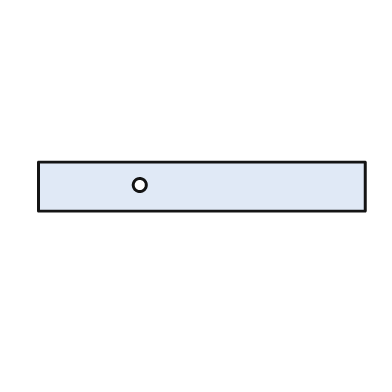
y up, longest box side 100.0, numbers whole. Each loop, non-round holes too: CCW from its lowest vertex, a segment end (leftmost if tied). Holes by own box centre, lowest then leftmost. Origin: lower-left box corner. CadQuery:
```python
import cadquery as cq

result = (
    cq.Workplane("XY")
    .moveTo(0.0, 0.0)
    .lineTo(100.0, 0.0)
    .lineTo(100.0, 15.0)
    .lineTo(0.0, 15.0)
    .close()
    .moveTo(31.0, 8.0)
    .circle(2.0)
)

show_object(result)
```